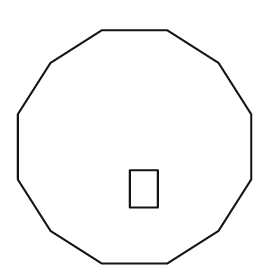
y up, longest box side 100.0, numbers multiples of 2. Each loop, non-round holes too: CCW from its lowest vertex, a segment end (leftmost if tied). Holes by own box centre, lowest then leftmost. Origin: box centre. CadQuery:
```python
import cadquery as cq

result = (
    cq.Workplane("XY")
    .moveTo(-14.0, -50.0)
    .lineTo(14.0, -50.0)
    .lineTo(36.0, -36.0)
    .lineTo(50.0, -14.0)
    .lineTo(50.0, 14.0)
    .lineTo(36.0, 36.0)
    .lineTo(14.0, 50.0)
    .lineTo(-14.0, 50.0)
    .lineTo(-36.0, 36.0)
    .lineTo(-50.0, 14.0)
    .lineTo(-50.0, -14.0)
    .lineTo(-36.0, -36.0)
    .close()
    .moveTo(-2.0, -26.0)
    .lineTo(10.0, -26.0)
    .lineTo(10.0, -10.0)
    .lineTo(-2.0, -10.0)
    .close()
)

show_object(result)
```